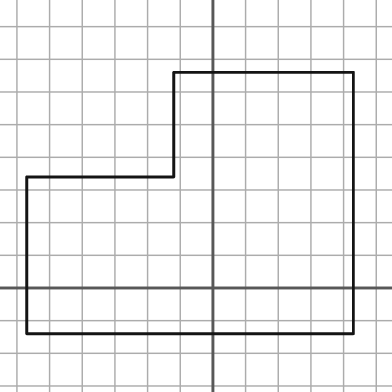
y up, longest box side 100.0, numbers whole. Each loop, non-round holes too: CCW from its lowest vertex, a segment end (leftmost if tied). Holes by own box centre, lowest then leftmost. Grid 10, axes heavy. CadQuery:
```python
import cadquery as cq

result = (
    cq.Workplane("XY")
    .moveTo(-57.0, -14.0)
    .lineTo(43.0, -14.0)
    .lineTo(43.0, 66.0)
    .lineTo(-12.0, 66.0)
    .lineTo(-12.0, 34.0)
    .lineTo(-57.0, 34.0)
    .close()
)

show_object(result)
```